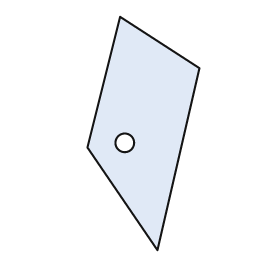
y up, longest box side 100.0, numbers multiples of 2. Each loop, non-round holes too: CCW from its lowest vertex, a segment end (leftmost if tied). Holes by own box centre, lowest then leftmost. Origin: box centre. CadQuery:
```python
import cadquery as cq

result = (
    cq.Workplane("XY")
    .moveTo(6.0, -50.0)
    .lineTo(24.0, 28.0)
    .lineTo(-10.0, 50.0)
    .lineTo(-24.0, -6.0)
    .close()
    .moveTo(-8.0, -4.0)
    .circle(4.0)
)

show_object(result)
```